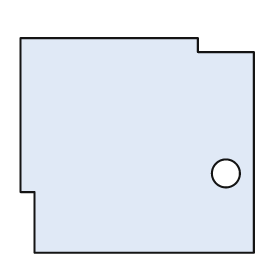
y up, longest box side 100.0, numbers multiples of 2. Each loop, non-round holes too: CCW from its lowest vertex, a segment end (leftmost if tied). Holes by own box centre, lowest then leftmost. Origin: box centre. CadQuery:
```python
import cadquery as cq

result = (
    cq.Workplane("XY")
    .moveTo(-44.0, -46.0)
    .lineTo(50.0, -46.0)
    .lineTo(50.0, 40.0)
    .lineTo(26.0, 40.0)
    .lineTo(26.0, 46.0)
    .lineTo(-50.0, 46.0)
    .lineTo(-50.0, -20.0)
    .lineTo(-44.0, -20.0)
    .close()
    .moveTo(38.0, -12.0)
    .circle(6.0)
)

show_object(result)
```